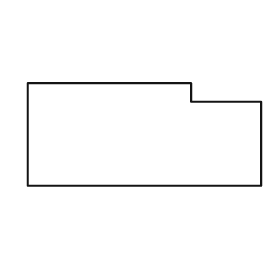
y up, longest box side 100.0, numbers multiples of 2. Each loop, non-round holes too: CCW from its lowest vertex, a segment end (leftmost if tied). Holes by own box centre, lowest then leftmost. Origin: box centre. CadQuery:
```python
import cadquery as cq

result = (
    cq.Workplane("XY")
    .moveTo(-50.0, -22.0)
    .lineTo(50.0, -22.0)
    .lineTo(50.0, 14.0)
    .lineTo(20.0, 14.0)
    .lineTo(20.0, 22.0)
    .lineTo(-50.0, 22.0)
    .close()
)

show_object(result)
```